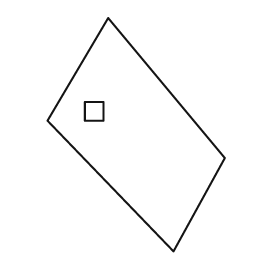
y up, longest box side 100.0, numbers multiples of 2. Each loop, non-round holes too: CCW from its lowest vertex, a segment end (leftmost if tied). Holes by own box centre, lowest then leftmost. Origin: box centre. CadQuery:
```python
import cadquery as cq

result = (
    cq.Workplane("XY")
    .moveTo(16.0, -50.0)
    .lineTo(38.0, -10.0)
    .lineTo(-12.0, 50.0)
    .lineTo(-38.0, 6.0)
    .close()
    .moveTo(-22.0, 6.0)
    .lineTo(-14.0, 6.0)
    .lineTo(-14.0, 14.0)
    .lineTo(-22.0, 14.0)
    .close()
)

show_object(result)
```